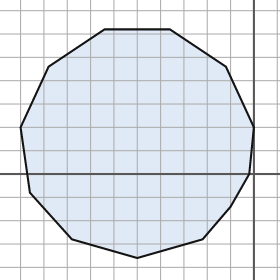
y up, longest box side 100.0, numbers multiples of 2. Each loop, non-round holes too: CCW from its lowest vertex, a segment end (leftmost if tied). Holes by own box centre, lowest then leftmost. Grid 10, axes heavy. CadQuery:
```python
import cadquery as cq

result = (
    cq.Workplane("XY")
    .moveTo(-50.0, -36.0)
    .lineTo(-22.0, -28.0)
    .lineTo(-10.0, -14.0)
    .lineTo(-2.0, 0.0)
    .lineTo(0.0, 20.0)
    .lineTo(-12.0, 46.0)
    .lineTo(-36.0, 62.0)
    .lineTo(-64.0, 62.0)
    .lineTo(-88.0, 46.0)
    .lineTo(-100.0, 20.0)
    .lineTo(-96.0, -8.0)
    .lineTo(-78.0, -28.0)
    .close()
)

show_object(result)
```